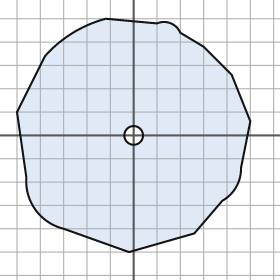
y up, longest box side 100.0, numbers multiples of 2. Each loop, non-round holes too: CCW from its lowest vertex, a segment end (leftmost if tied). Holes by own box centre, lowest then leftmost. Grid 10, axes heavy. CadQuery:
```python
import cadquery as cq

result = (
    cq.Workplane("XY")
    .moveTo(-2.0, -50.0)
    .lineTo(26.0, -42.0)
    .lineTo(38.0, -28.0)
    .threePointArc((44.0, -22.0), (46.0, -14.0))
    .lineTo(50.0, 6.0)
    .lineTo(42.0, 26.0)
    .lineTo(30.0, 38.0)
    .lineTo(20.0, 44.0)
    .threePointArc((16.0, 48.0), (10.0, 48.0))
    .lineTo(-12.0, 50.0)
    .threePointArc((-26.0, 44.0), (-38.0, 34.0))
    .lineTo(-50.0, 10.0)
    .lineTo(-46.0, -18.0)
    .threePointArc((-42.0, -32.0), (-30.0, -40.0))
    .close()
    .moveTo(0.0, 0.0)
    .circle(4.0)
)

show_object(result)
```